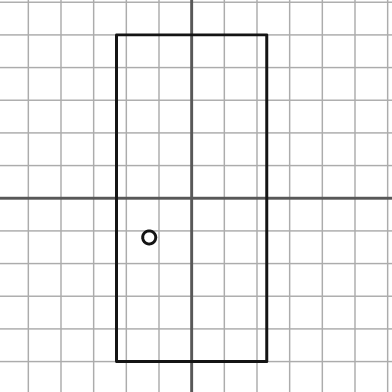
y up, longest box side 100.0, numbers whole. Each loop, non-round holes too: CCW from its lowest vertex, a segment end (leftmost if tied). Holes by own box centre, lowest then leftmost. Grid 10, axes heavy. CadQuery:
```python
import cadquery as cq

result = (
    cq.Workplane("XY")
    .moveTo(-23.0, -50.0)
    .lineTo(23.0, -50.0)
    .lineTo(23.0, 50.0)
    .lineTo(-23.0, 50.0)
    .close()
    .moveTo(-13.0, -12.0)
    .circle(2.0)
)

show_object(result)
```